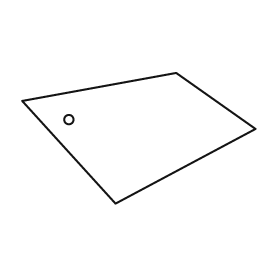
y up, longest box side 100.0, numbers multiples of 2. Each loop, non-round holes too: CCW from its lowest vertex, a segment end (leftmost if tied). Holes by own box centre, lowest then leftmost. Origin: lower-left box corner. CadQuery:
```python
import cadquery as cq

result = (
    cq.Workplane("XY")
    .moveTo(40.0, 0.0)
    .lineTo(100.0, 32.0)
    .lineTo(66.0, 56.0)
    .lineTo(0.0, 44.0)
    .close()
    .moveTo(20.0, 36.0)
    .circle(2.0)
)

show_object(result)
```